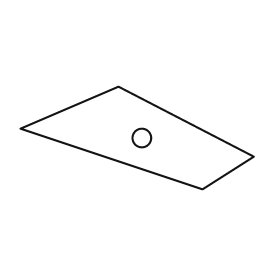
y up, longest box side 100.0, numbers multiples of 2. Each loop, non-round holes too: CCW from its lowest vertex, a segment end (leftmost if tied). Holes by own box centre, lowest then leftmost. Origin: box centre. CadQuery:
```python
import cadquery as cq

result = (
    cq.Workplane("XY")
    .moveTo(28.0, -22.0)
    .lineTo(50.0, -8.0)
    .lineTo(-8.0, 22.0)
    .lineTo(-50.0, 4.0)
    .close()
    .moveTo(2.0, 0.0)
    .circle(4.0)
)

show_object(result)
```